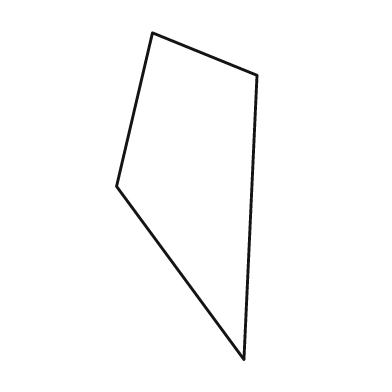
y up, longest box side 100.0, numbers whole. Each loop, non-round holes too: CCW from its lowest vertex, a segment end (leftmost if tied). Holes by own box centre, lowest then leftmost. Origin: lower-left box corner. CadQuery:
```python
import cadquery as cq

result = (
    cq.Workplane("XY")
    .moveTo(39.0, 0.0)
    .lineTo(43.0, 87.0)
    .lineTo(11.0, 100.0)
    .lineTo(0.0, 53.0)
    .close()
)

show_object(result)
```